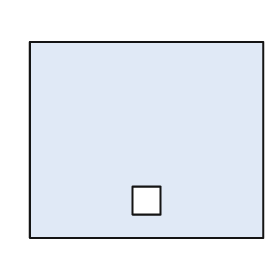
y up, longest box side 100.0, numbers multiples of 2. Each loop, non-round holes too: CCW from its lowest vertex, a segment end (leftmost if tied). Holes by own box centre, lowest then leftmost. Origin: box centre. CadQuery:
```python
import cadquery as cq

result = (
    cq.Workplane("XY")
    .moveTo(-50.0, -42.0)
    .lineTo(50.0, -42.0)
    .lineTo(50.0, 42.0)
    .lineTo(-50.0, 42.0)
    .close()
    .moveTo(-6.0, -32.0)
    .lineTo(6.0, -32.0)
    .lineTo(6.0, -20.0)
    .lineTo(-6.0, -20.0)
    .close()
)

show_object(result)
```